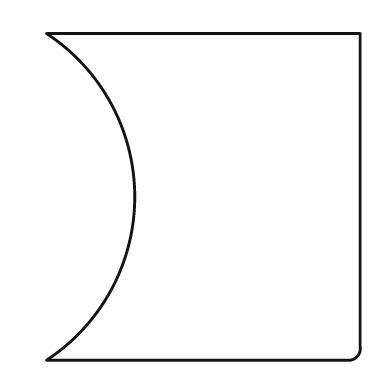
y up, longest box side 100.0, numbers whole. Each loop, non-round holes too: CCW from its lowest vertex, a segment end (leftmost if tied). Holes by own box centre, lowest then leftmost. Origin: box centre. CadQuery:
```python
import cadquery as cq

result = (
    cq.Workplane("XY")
    .moveTo(-48.0, -50.0)
    .lineTo(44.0, -50.0)
    .threePointArc((47.0, -49.0), (48.0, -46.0))
    .lineTo(48.0, 50.0)
    .lineTo(-48.0, 50.0)
    .threePointArc((-21.0, 0.0), (-48.0, -50.0))
    .close()
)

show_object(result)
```